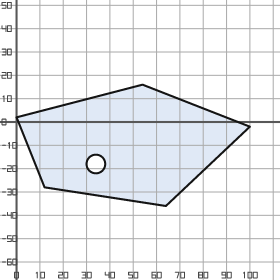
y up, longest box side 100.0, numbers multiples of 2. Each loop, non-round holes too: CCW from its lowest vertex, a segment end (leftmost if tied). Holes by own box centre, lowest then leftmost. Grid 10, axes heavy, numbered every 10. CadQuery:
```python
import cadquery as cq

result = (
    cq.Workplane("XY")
    .moveTo(64.0, -36.0)
    .lineTo(100.0, -2.0)
    .lineTo(54.0, 16.0)
    .lineTo(0.0, 2.0)
    .lineTo(12.0, -28.0)
    .close()
    .moveTo(34.0, -18.0)
    .circle(4.0)
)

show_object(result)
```